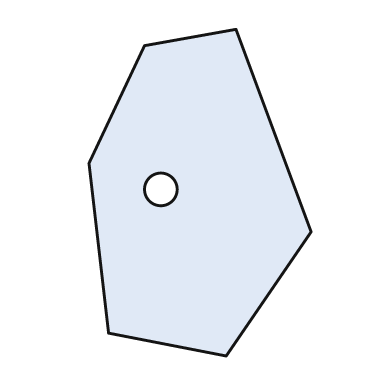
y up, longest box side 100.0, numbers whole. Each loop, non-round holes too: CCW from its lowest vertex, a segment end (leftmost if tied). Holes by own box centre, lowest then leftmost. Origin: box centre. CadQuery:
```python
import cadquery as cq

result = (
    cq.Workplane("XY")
    .moveTo(8.0, -50.0)
    .lineTo(34.0, -12.0)
    .lineTo(11.0, 50.0)
    .lineTo(-17.0, 45.0)
    .lineTo(-34.0, 9.0)
    .lineTo(-28.0, -43.0)
    .close()
    .moveTo(-12.0, 1.0)
    .circle(5.0)
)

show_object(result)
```